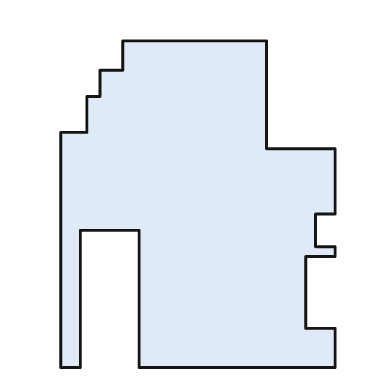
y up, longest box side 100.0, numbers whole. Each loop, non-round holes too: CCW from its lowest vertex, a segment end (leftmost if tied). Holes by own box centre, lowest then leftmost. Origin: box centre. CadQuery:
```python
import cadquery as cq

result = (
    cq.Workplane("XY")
    .moveTo(-42.0, -50.0)
    .lineTo(-36.0, -50.0)
    .lineTo(-36.0, -8.0)
    .lineTo(-18.0, -8.0)
    .lineTo(-18.0, -50.0)
    .lineTo(42.0, -50.0)
    .lineTo(42.0, -38.0)
    .lineTo(33.0, -38.0)
    .lineTo(33.0, -16.0)
    .lineTo(42.0, -16.0)
    .lineTo(42.0, -13.0)
    .lineTo(36.0, -13.0)
    .lineTo(36.0, -3.0)
    .lineTo(42.0, -3.0)
    .lineTo(42.0, 17.0)
    .lineTo(21.0, 17.0)
    .lineTo(21.0, 50.0)
    .lineTo(-23.0, 50.0)
    .lineTo(-23.0, 41.0)
    .lineTo(-30.0, 41.0)
    .lineTo(-30.0, 33.0)
    .lineTo(-34.0, 33.0)
    .lineTo(-34.0, 22.0)
    .lineTo(-42.0, 22.0)
    .close()
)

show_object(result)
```